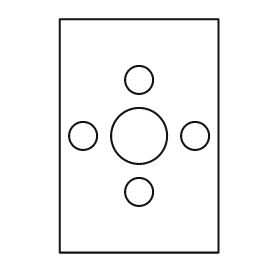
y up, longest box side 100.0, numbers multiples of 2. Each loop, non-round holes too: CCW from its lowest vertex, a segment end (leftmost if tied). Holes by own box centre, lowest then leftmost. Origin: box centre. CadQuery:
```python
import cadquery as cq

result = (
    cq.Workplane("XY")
    .moveTo(-34.0, -50.0)
    .lineTo(34.0, -50.0)
    .lineTo(34.0, 50.0)
    .lineTo(-34.0, 50.0)
    .close()
    .moveTo(0.0, -24.0)
    .circle(6.0)
    .moveTo(-24.0, 0.0)
    .circle(6.0)
    .moveTo(0.0, 0.0)
    .circle(12.0)
    .moveTo(24.0, 0.0)
    .circle(6.0)
    .moveTo(0.0, 24.0)
    .circle(6.0)
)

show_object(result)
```